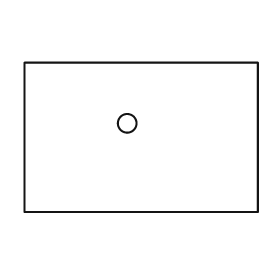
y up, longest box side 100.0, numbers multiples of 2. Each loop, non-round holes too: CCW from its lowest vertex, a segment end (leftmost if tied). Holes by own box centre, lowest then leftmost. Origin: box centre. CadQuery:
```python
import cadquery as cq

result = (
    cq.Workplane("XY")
    .moveTo(-50.0, -32.0)
    .lineTo(50.0, -32.0)
    .lineTo(50.0, 32.0)
    .lineTo(-50.0, 32.0)
    .close()
    .moveTo(-6.0, 6.0)
    .circle(4.0)
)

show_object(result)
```